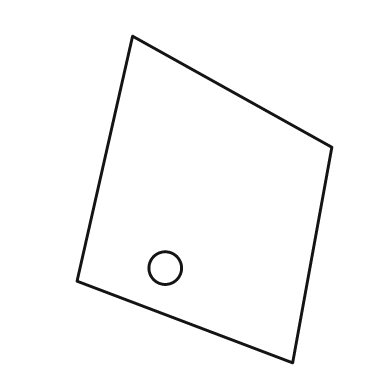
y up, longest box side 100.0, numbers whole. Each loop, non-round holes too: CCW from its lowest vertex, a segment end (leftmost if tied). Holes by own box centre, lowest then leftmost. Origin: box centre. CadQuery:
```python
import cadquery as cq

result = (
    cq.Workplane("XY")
    .moveTo(27.0, -50.0)
    .lineTo(39.0, 16.0)
    .lineTo(-22.0, 50.0)
    .lineTo(-39.0, -25.0)
    .close()
    .moveTo(-12.0, -21.0)
    .circle(5.0)
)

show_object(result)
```